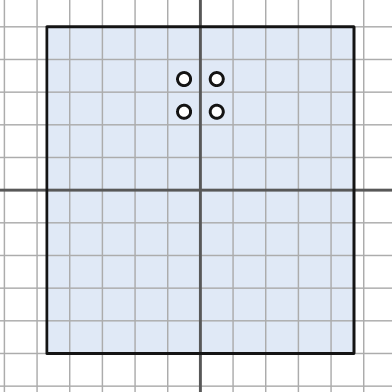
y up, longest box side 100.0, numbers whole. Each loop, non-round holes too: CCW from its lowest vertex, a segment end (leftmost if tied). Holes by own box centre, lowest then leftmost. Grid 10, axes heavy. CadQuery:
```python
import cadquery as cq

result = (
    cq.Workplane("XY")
    .moveTo(-47.0, -50.0)
    .lineTo(47.0, -50.0)
    .lineTo(47.0, 50.0)
    .lineTo(-47.0, 50.0)
    .close()
    .moveTo(-5.0, 24.0)
    .circle(2.0)
    .moveTo(5.0, 24.0)
    .circle(2.0)
    .moveTo(-5.0, 34.0)
    .circle(2.0)
    .moveTo(5.0, 34.0)
    .circle(2.0)
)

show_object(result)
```